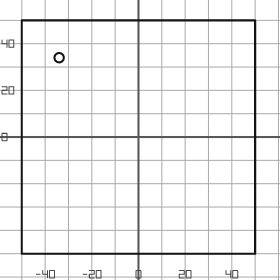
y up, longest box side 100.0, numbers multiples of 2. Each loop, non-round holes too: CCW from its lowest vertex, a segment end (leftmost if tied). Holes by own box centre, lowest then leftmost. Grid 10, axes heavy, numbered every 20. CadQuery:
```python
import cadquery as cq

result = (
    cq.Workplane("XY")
    .moveTo(-50.0, -50.0)
    .lineTo(50.0, -50.0)
    .lineTo(50.0, 50.0)
    .lineTo(-50.0, 50.0)
    .close()
    .moveTo(-34.0, 34.0)
    .circle(2.0)
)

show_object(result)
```